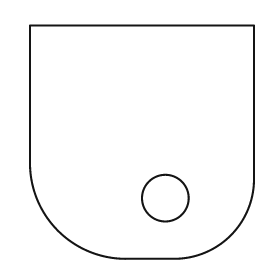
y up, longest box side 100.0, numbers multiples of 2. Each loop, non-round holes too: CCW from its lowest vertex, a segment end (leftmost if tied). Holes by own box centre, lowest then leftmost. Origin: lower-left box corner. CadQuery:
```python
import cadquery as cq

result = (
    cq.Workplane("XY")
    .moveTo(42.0, 0.0)
    .lineTo(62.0, 0.0)
    .threePointArc((86.0, 10.0), (96.0, 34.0))
    .lineTo(96.0, 100.0)
    .lineTo(0.0, 100.0)
    .lineTo(0.0, 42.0)
    .threePointArc((12.0, 12.0), (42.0, 0.0))
    .close()
    .moveTo(58.0, 26.0)
    .circle(10.0)
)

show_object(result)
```